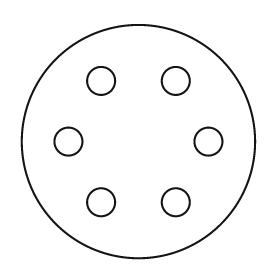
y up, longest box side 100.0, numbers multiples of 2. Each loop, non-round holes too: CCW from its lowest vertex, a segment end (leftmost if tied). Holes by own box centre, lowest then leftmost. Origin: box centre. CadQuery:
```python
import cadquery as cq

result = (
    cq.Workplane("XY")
    .moveTo(0.0, 0.0)
    .circle(50.0)
    .moveTo(-16.0, -26.0)
    .circle(6.0)
    .moveTo(16.0, -26.0)
    .circle(6.0)
    .moveTo(-30.0, 0.0)
    .circle(6.0)
    .moveTo(30.0, 0.0)
    .circle(6.0)
    .moveTo(-16.0, 26.0)
    .circle(6.0)
    .moveTo(16.0, 26.0)
    .circle(6.0)
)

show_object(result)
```